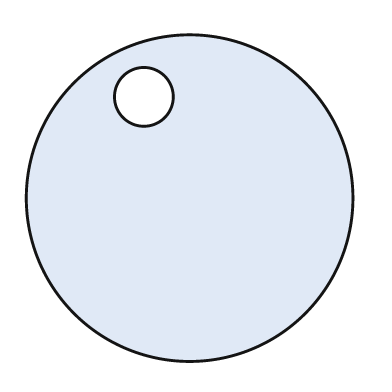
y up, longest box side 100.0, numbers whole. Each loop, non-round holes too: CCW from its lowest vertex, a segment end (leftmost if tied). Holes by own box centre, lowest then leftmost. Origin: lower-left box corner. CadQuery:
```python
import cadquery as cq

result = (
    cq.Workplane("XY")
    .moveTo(50.0, 50.0)
    .circle(50.0)
    .moveTo(36.0, 81.0)
    .circle(9.0)
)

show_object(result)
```